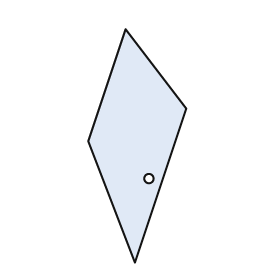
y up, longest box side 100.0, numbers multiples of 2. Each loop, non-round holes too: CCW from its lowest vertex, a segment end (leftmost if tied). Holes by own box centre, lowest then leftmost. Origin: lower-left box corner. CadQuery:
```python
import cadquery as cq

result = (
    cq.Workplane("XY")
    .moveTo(20.0, 0.0)
    .lineTo(42.0, 66.0)
    .lineTo(16.0, 100.0)
    .lineTo(0.0, 52.0)
    .close()
    .moveTo(26.0, 36.0)
    .circle(2.0)
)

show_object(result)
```